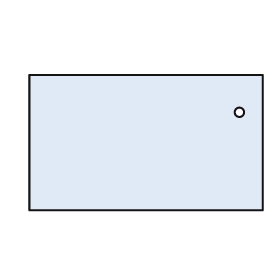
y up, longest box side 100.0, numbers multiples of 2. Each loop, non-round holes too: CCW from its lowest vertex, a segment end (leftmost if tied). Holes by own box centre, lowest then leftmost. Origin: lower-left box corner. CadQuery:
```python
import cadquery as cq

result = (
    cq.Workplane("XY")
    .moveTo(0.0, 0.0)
    .lineTo(100.0, 0.0)
    .lineTo(100.0, 58.0)
    .lineTo(0.0, 58.0)
    .close()
    .moveTo(90.0, 42.0)
    .circle(2.0)
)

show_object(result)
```